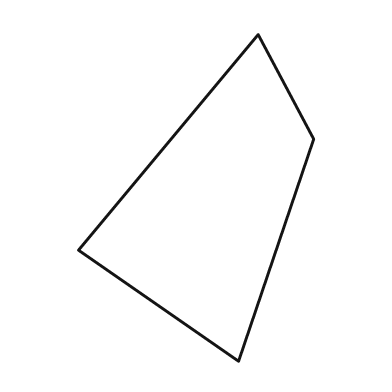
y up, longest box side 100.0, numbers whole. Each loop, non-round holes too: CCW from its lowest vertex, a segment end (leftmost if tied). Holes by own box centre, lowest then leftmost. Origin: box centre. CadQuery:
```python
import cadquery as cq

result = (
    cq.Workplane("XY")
    .moveTo(13.0, -50.0)
    .lineTo(36.0, 18.0)
    .lineTo(19.0, 50.0)
    .lineTo(-36.0, -16.0)
    .close()
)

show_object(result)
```